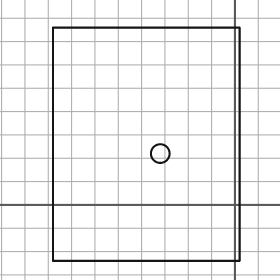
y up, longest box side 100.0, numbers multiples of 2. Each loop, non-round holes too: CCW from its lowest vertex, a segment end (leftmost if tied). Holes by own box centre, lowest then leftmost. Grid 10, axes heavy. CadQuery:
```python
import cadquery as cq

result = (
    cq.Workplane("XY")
    .moveTo(-78.0, -24.0)
    .lineTo(2.0, -24.0)
    .lineTo(2.0, 76.0)
    .lineTo(-78.0, 76.0)
    .close()
    .moveTo(-32.0, 22.0)
    .circle(4.0)
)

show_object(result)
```